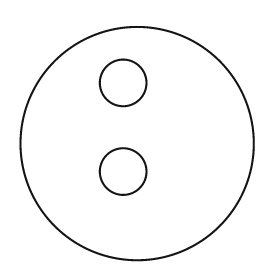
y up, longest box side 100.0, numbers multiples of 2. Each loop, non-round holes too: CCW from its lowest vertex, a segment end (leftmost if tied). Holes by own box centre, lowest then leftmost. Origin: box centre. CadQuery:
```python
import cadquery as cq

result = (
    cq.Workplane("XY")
    .moveTo(0.0, 0.0)
    .circle(50.0)
    .moveTo(-6.0, -12.0)
    .circle(10.0)
    .moveTo(-6.0, 26.0)
    .circle(10.0)
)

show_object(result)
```